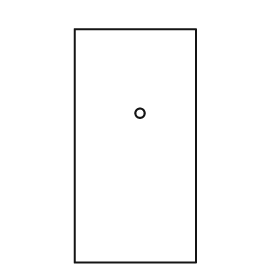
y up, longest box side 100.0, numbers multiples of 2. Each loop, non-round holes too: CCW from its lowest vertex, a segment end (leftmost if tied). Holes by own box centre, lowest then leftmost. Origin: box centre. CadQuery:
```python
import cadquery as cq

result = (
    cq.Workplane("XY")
    .moveTo(-26.0, -50.0)
    .lineTo(26.0, -50.0)
    .lineTo(26.0, 50.0)
    .lineTo(-26.0, 50.0)
    .close()
    .moveTo(2.0, 14.0)
    .circle(2.0)
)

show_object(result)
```